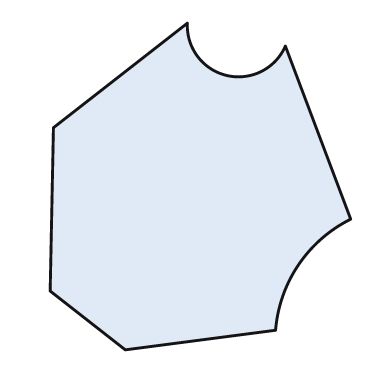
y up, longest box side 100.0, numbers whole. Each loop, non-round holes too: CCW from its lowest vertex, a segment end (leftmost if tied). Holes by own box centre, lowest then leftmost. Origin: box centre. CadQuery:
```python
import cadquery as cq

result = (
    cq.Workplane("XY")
    .moveTo(-23.0, -50.0)
    .lineTo(23.0, -44.0)
    .threePointArc((30.0, -24.0), (46.0, -10.0))
    .lineTo(26.0, 43.0)
    .threePointArc((8.0, 34.0), (-4.0, 50.0))
    .lineTo(-45.0, 18.0)
    .lineTo(-46.0, -32.0)
    .close()
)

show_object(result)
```